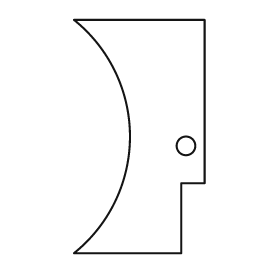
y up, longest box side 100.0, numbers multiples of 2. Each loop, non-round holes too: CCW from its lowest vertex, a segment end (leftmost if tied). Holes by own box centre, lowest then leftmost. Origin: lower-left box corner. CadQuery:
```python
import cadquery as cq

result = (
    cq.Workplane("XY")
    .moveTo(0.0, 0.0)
    .lineTo(46.0, 0.0)
    .lineTo(46.0, 30.0)
    .lineTo(56.0, 30.0)
    .lineTo(56.0, 100.0)
    .lineTo(0.0, 100.0)
    .threePointArc((24.0, 50.0), (0.0, 0.0))
    .close()
    .moveTo(48.0, 46.0)
    .circle(4.0)
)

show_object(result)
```